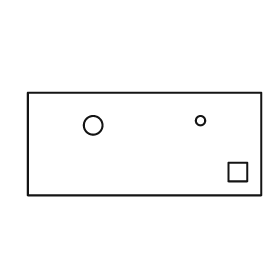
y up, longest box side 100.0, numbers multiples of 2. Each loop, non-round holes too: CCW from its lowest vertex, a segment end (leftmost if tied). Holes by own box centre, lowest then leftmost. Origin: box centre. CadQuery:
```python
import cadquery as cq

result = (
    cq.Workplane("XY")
    .moveTo(-50.0, -22.0)
    .lineTo(50.0, -22.0)
    .lineTo(50.0, 22.0)
    .lineTo(-50.0, 22.0)
    .close()
    .moveTo(36.0, -16.0)
    .lineTo(44.0, -16.0)
    .lineTo(44.0, -8.0)
    .lineTo(36.0, -8.0)
    .close()
    .moveTo(-22.0, 8.0)
    .circle(4.0)
    .moveTo(24.0, 10.0)
    .circle(2.0)
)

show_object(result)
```